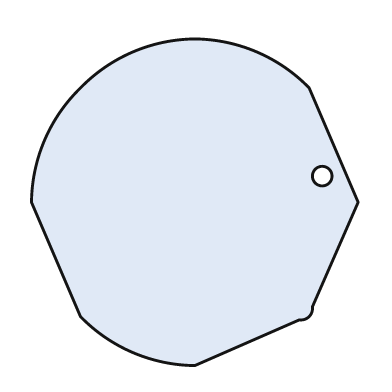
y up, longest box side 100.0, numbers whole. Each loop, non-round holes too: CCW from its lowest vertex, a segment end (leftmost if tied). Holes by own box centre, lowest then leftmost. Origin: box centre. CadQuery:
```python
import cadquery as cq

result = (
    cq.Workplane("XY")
    .moveTo(0.0, -50.0)
    .lineTo(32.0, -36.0)
    .threePointArc((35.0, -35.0), (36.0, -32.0))
    .lineTo(50.0, 0.0)
    .lineTo(35.0, 35.0)
    .threePointArc((19.0, 46.0), (0.0, 50.0))
    .threePointArc((-19.0, 46.0), (-35.0, 35.0))
    .threePointArc((-46.0, 19.0), (-50.0, 0.0))
    .lineTo(-35.0, -35.0)
    .threePointArc((-19.0, -46.0), (0.0, -50.0))
    .close()
    .moveTo(39.0, 8.0)
    .circle(3.0)
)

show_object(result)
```